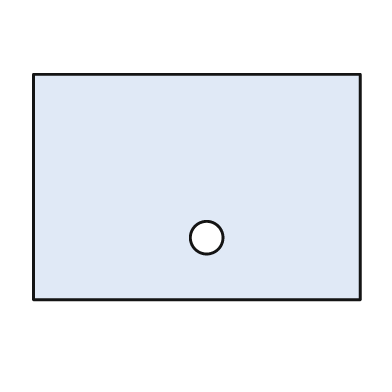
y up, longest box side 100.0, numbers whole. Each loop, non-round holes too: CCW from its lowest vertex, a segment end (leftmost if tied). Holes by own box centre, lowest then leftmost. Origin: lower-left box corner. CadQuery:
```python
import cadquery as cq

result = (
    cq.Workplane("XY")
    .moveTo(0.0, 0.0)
    .lineTo(100.0, 0.0)
    .lineTo(100.0, 69.0)
    .lineTo(0.0, 69.0)
    .close()
    .moveTo(53.0, 19.0)
    .circle(5.0)
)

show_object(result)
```